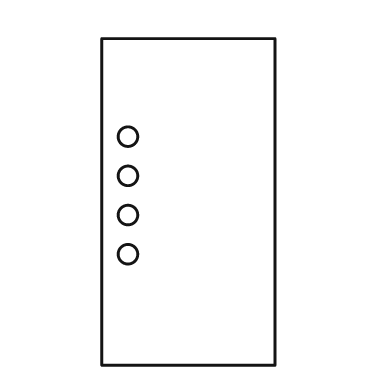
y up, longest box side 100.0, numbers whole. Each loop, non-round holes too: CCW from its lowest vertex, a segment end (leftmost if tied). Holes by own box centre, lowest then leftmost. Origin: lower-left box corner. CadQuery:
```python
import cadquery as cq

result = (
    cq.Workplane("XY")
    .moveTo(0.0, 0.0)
    .lineTo(53.0, 0.0)
    .lineTo(53.0, 100.0)
    .lineTo(0.0, 100.0)
    .close()
    .moveTo(8.0, 34.0)
    .circle(3.0)
    .moveTo(8.0, 46.0)
    .circle(3.0)
    .moveTo(8.0, 58.0)
    .circle(3.0)
    .moveTo(8.0, 70.0)
    .circle(3.0)
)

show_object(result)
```